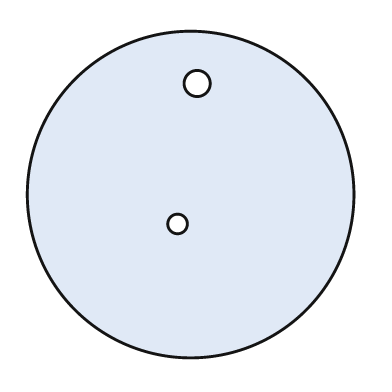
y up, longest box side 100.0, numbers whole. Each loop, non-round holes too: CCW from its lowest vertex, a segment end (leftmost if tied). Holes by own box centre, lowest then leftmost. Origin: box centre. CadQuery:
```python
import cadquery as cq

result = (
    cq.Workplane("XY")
    .moveTo(0.0, 0.0)
    .circle(50.0)
    .moveTo(-4.0, -9.0)
    .circle(3.0)
    .moveTo(2.0, 34.0)
    .circle(4.0)
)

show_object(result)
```